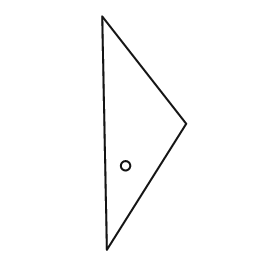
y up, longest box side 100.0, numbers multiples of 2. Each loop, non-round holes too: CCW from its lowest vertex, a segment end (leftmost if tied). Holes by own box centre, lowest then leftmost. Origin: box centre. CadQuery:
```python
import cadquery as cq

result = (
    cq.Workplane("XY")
    .moveTo(-16.0, -50.0)
    .lineTo(18.0, 4.0)
    .lineTo(-18.0, 50.0)
    .close()
    .moveTo(-8.0, -14.0)
    .circle(2.0)
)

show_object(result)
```